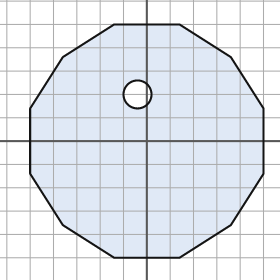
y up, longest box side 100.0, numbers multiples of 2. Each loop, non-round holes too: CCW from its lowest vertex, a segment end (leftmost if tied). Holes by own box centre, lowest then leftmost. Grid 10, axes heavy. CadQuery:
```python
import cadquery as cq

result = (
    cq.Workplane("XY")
    .moveTo(-14.0, -50.0)
    .lineTo(14.0, -50.0)
    .lineTo(36.0, -36.0)
    .lineTo(50.0, -14.0)
    .lineTo(50.0, 14.0)
    .lineTo(36.0, 36.0)
    .lineTo(14.0, 50.0)
    .lineTo(-14.0, 50.0)
    .lineTo(-36.0, 36.0)
    .lineTo(-50.0, 14.0)
    .lineTo(-50.0, -14.0)
    .lineTo(-36.0, -36.0)
    .close()
    .moveTo(-4.0, 20.0)
    .circle(6.0)
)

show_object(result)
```